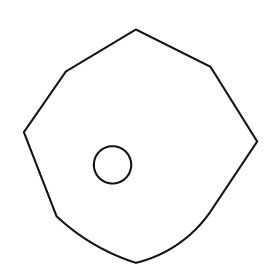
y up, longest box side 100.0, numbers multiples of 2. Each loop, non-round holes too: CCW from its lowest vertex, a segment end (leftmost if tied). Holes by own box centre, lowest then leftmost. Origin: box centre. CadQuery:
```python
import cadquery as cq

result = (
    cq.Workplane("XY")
    .moveTo(-2.0, -50.0)
    .threePointArc((16.0, -42.0), (30.0, -28.0))
    .lineTo(50.0, 2.0)
    .lineTo(30.0, 34.0)
    .lineTo(-2.0, 50.0)
    .lineTo(-32.0, 32.0)
    .lineTo(-50.0, 6.0)
    .lineTo(-36.0, -30.0)
    .threePointArc((-20.0, -42.0), (-2.0, -50.0))
    .close()
    .moveTo(-12.0, -8.0)
    .circle(8.0)
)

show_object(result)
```